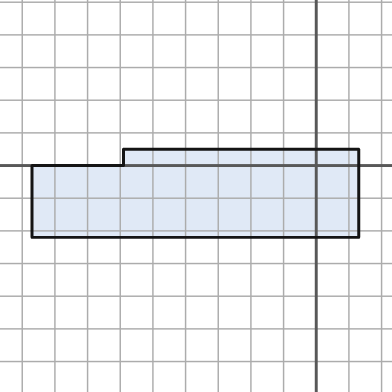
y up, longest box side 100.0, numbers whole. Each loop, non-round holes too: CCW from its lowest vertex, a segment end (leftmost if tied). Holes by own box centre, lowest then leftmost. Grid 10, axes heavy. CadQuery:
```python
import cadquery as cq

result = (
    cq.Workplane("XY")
    .moveTo(-87.0, -22.0)
    .lineTo(13.0, -22.0)
    .lineTo(13.0, 5.0)
    .lineTo(-59.0, 5.0)
    .lineTo(-59.0, 0.0)
    .lineTo(-87.0, 0.0)
    .close()
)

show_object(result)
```